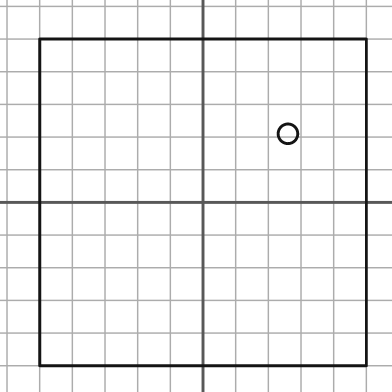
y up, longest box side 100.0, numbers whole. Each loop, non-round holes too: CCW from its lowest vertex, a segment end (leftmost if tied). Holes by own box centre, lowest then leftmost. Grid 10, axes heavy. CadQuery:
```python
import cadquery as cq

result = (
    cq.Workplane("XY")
    .moveTo(-50.0, -50.0)
    .lineTo(50.0, -50.0)
    .lineTo(50.0, 50.0)
    .lineTo(-50.0, 50.0)
    .close()
    .moveTo(26.0, 21.0)
    .circle(3.0)
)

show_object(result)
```